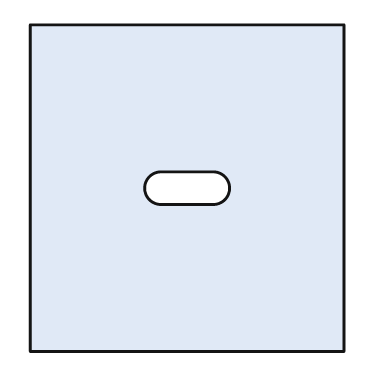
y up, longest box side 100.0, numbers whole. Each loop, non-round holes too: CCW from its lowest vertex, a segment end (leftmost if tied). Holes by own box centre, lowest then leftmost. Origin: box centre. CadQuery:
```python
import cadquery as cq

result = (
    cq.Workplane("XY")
    .moveTo(-48.0, -50.0)
    .lineTo(48.0, -50.0)
    .lineTo(48.0, 50.0)
    .lineTo(-48.0, 50.0)
    .close()
    .moveTo(-8.0, -5.0)
    .lineTo(8.0, -5.0)
    .threePointArc((13.0, 0.0), (8.0, 5.0))
    .lineTo(-8.0, 5.0)
    .threePointArc((-13.0, 0.0), (-8.0, -5.0))
    .close()
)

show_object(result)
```